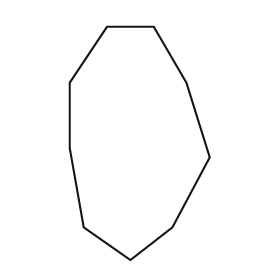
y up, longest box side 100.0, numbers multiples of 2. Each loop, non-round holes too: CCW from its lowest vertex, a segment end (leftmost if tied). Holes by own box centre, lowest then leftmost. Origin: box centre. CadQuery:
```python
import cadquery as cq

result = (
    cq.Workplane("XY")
    .moveTo(-4.0, -50.0)
    .lineTo(14.0, -36.0)
    .lineTo(30.0, -6.0)
    .lineTo(20.0, 26.0)
    .lineTo(6.0, 50.0)
    .lineTo(-14.0, 50.0)
    .lineTo(-30.0, 26.0)
    .lineTo(-30.0, -2.0)
    .lineTo(-24.0, -36.0)
    .close()
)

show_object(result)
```